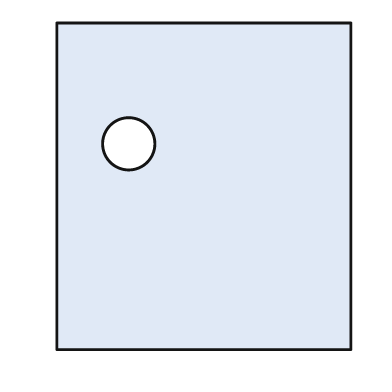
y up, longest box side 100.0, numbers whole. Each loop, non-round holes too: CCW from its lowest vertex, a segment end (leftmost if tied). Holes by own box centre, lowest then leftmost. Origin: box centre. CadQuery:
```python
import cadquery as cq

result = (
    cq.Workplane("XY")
    .moveTo(-45.0, -50.0)
    .lineTo(45.0, -50.0)
    .lineTo(45.0, 50.0)
    .lineTo(-45.0, 50.0)
    .close()
    .moveTo(-23.0, 13.0)
    .circle(8.0)
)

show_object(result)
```